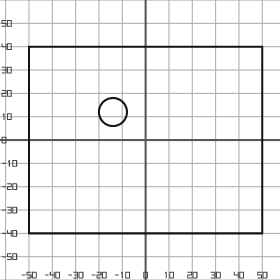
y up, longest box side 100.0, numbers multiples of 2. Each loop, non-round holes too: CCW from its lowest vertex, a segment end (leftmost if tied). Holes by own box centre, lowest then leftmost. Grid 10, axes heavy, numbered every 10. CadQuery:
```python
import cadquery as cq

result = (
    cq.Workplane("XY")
    .moveTo(-50.0, -40.0)
    .lineTo(50.0, -40.0)
    .lineTo(50.0, 40.0)
    .lineTo(-50.0, 40.0)
    .close()
    .moveTo(-14.0, 12.0)
    .circle(6.0)
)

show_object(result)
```